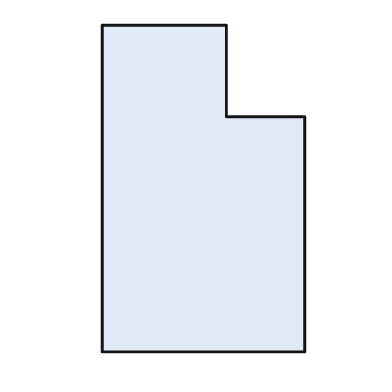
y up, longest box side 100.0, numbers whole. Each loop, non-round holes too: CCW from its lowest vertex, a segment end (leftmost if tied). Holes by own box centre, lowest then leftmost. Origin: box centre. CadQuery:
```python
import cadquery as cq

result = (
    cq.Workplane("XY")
    .moveTo(-31.0, -50.0)
    .lineTo(31.0, -50.0)
    .lineTo(31.0, 22.0)
    .lineTo(7.0, 22.0)
    .lineTo(7.0, 50.0)
    .lineTo(-31.0, 50.0)
    .close()
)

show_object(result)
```